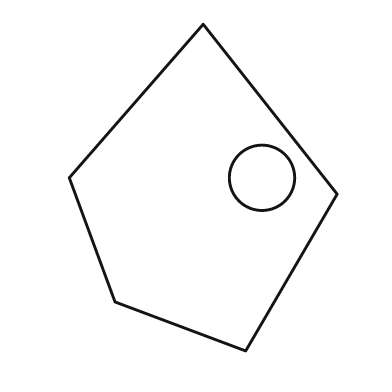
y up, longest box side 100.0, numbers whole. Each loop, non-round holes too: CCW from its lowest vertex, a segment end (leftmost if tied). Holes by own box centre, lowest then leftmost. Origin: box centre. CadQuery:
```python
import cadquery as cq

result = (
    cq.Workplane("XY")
    .moveTo(13.0, -50.0)
    .lineTo(41.0, -2.0)
    .lineTo(0.0, 50.0)
    .lineTo(-41.0, 3.0)
    .lineTo(-27.0, -35.0)
    .close()
    .moveTo(18.0, 3.0)
    .circle(10.0)
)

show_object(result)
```